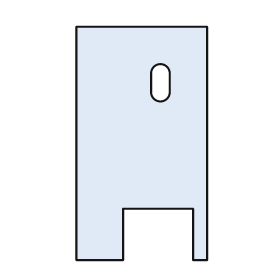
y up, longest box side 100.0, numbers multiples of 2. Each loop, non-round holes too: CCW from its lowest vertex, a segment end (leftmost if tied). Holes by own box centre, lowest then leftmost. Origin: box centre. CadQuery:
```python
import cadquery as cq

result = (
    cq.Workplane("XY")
    .moveTo(-28.0, -50.0)
    .lineTo(-8.0, -50.0)
    .lineTo(-8.0, -28.0)
    .lineTo(22.0, -28.0)
    .lineTo(22.0, -50.0)
    .lineTo(28.0, -50.0)
    .lineTo(28.0, 50.0)
    .lineTo(-28.0, 50.0)
    .close()
    .moveTo(4.0, 22.0)
    .threePointArc((8.0, 18.0), (12.0, 22.0))
    .lineTo(12.0, 30.0)
    .threePointArc((8.0, 34.0), (4.0, 30.0))
    .close()
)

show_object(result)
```